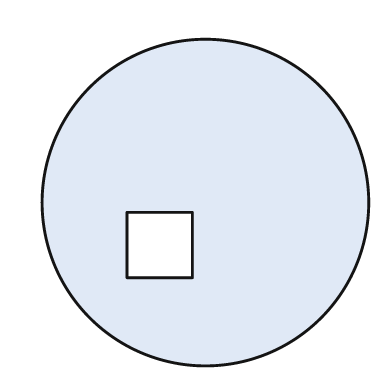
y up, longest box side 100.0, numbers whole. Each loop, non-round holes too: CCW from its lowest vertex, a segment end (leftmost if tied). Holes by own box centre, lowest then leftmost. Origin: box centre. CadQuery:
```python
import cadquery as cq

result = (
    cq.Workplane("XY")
    .moveTo(0.0, 0.0)
    .circle(50.0)
    .moveTo(-24.0, -23.0)
    .lineTo(-4.0, -23.0)
    .lineTo(-4.0, -3.0)
    .lineTo(-24.0, -3.0)
    .close()
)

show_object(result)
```